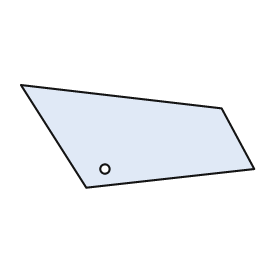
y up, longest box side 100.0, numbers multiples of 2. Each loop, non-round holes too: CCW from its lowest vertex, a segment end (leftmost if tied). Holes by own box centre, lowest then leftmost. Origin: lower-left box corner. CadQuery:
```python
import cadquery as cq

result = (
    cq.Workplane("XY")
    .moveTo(28.0, 0.0)
    .lineTo(100.0, 8.0)
    .lineTo(86.0, 34.0)
    .lineTo(0.0, 44.0)
    .close()
    .moveTo(36.0, 8.0)
    .circle(2.0)
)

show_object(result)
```